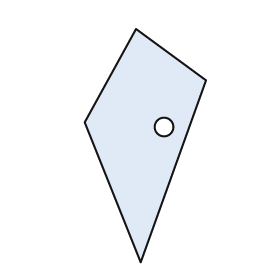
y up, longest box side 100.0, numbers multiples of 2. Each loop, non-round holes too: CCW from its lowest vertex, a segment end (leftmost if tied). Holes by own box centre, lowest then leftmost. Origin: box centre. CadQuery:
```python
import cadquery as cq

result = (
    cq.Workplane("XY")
    .moveTo(-2.0, -50.0)
    .lineTo(26.0, 28.0)
    .lineTo(-4.0, 50.0)
    .lineTo(-26.0, 10.0)
    .close()
    .moveTo(8.0, 8.0)
    .circle(4.0)
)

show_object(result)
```